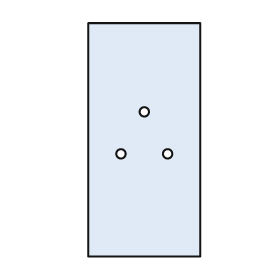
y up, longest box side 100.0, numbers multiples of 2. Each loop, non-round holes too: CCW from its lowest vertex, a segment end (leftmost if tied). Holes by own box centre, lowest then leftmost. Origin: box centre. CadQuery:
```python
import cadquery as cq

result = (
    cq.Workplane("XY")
    .moveTo(-24.0, -50.0)
    .lineTo(24.0, -50.0)
    .lineTo(24.0, 50.0)
    .lineTo(-24.0, 50.0)
    .close()
    .moveTo(-10.0, -6.0)
    .circle(2.0)
    .moveTo(10.0, -6.0)
    .circle(2.0)
    .moveTo(0.0, 12.0)
    .circle(2.0)
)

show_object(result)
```